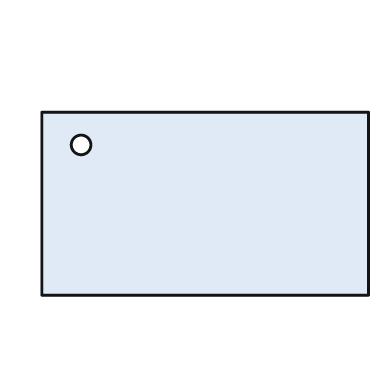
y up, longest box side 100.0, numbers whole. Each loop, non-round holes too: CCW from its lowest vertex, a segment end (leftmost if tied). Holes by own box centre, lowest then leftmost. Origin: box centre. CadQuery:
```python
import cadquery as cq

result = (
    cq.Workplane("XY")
    .moveTo(-50.0, -28.0)
    .lineTo(50.0, -28.0)
    .lineTo(50.0, 28.0)
    .lineTo(-50.0, 28.0)
    .close()
    .moveTo(-38.0, 18.0)
    .circle(3.0)
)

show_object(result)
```